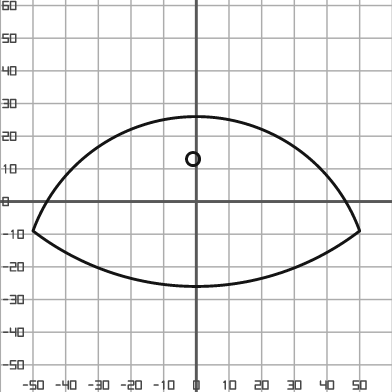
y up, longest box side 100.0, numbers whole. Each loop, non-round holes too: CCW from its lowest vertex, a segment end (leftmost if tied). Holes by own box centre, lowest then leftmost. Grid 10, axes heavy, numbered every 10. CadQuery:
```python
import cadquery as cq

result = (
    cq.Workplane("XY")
    .moveTo(-50.0, -9.0)
    .threePointArc((0.0, -26.0), (50.0, -9.0))
    .threePointArc((0.0, 26.0), (-50.0, -9.0))
    .close()
    .moveTo(-1.0, 13.0)
    .circle(2.0)
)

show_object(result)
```